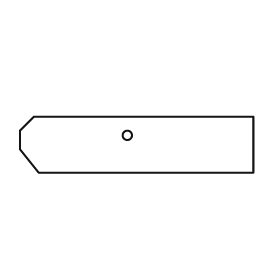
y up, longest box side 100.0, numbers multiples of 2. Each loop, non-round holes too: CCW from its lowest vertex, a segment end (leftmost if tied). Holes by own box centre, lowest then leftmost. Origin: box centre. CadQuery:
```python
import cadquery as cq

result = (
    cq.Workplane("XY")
    .moveTo(-42.0, -12.0)
    .lineTo(50.0, -12.0)
    .lineTo(50.0, 12.0)
    .lineTo(-44.0, 12.0)
    .lineTo(-50.0, 6.0)
    .lineTo(-50.0, -2.0)
    .close()
    .moveTo(-4.0, 4.0)
    .circle(2.0)
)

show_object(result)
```